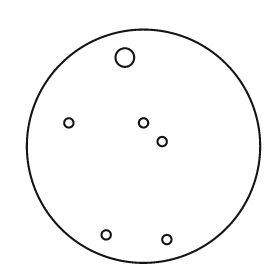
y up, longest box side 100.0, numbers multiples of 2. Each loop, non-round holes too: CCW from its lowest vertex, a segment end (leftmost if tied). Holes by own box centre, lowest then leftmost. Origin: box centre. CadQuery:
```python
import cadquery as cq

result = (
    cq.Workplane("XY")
    .moveTo(0.0, 0.0)
    .circle(50.0)
    .moveTo(10.0, -40.0)
    .circle(2.0)
    .moveTo(-16.0, -38.0)
    .circle(2.0)
    .moveTo(8.0, 2.0)
    .circle(2.0)
    .moveTo(-32.0, 10.0)
    .circle(2.0)
    .moveTo(0.0, 10.0)
    .circle(2.0)
    .moveTo(-8.0, 38.0)
    .circle(4.0)
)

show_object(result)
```